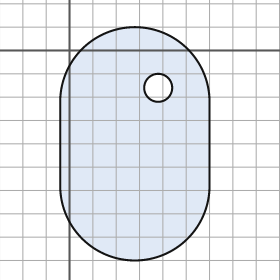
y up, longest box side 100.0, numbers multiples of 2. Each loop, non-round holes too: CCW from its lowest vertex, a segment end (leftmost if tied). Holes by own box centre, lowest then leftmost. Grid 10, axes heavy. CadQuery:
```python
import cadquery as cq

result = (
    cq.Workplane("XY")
    .moveTo(-4.0, -58.0)
    .threePointArc((28.0, -90.0), (60.0, -58.0))
    .lineTo(60.0, -22.0)
    .threePointArc((28.0, 10.0), (-4.0, -22.0))
    .close()
    .moveTo(38.0, -16.0)
    .circle(6.0)
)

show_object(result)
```